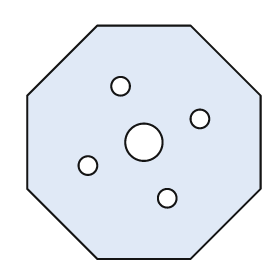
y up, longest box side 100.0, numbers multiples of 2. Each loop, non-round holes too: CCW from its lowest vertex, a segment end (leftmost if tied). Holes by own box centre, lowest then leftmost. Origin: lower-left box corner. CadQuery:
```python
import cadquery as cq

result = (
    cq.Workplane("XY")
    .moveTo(30.0, 0.0)
    .lineTo(70.0, 0.0)
    .lineTo(100.0, 30.0)
    .lineTo(100.0, 70.0)
    .lineTo(70.0, 100.0)
    .lineTo(30.0, 100.0)
    .lineTo(0.0, 70.0)
    .lineTo(0.0, 30.0)
    .close()
    .moveTo(60.0, 26.0)
    .circle(4.0)
    .moveTo(26.0, 40.0)
    .circle(4.0)
    .moveTo(50.0, 50.0)
    .circle(8.0)
    .moveTo(74.0, 60.0)
    .circle(4.0)
    .moveTo(40.0, 74.0)
    .circle(4.0)
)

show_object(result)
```